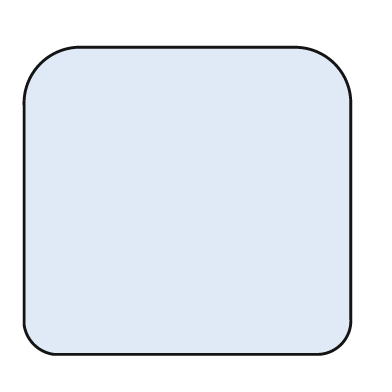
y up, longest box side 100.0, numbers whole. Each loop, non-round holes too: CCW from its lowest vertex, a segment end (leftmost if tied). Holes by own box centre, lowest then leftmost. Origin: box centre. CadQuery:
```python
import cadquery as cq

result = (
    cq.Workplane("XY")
    .moveTo(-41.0, -47.0)
    .lineTo(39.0, -47.0)
    .threePointArc((47.0, -44.0), (50.0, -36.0))
    .lineTo(50.0, 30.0)
    .threePointArc((45.0, 42.0), (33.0, 47.0))
    .lineTo(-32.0, 47.0)
    .threePointArc((-45.0, 42.0), (-50.0, 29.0))
    .lineTo(-50.0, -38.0)
    .threePointArc((-47.0, -44.0), (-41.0, -47.0))
    .close()
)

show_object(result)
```